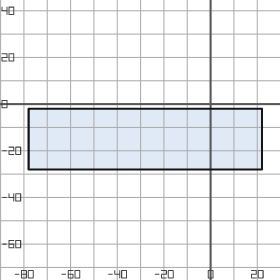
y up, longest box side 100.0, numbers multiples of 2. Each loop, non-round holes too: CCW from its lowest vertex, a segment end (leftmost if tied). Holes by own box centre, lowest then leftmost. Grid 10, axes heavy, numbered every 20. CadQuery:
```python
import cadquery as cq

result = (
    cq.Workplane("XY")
    .moveTo(-78.0, -28.0)
    .lineTo(22.0, -28.0)
    .lineTo(22.0, -2.0)
    .lineTo(-78.0, -2.0)
    .close()
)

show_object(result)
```